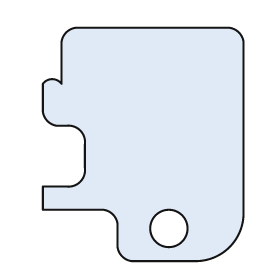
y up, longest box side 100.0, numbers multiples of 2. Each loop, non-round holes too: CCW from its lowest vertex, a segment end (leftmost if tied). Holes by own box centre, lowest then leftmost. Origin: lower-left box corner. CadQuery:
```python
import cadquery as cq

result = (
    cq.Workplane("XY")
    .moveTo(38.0, 0.0)
    .lineTo(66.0, 0.0)
    .threePointArc((80.0, 6.0), (86.0, 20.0))
    .lineTo(86.0, 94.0)
    .threePointArc((84.0, 98.0), (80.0, 100.0))
    .lineTo(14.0, 100.0)
    .threePointArc((10.0, 98.0), (8.0, 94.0))
    .lineTo(8.0, 76.0)
    .threePointArc((4.0, 78.0), (0.0, 76.0))
    .lineTo(0.0, 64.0)
    .threePointArc((2.0, 60.0), (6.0, 58.0))
    .lineTo(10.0, 58.0)
    .threePointArc((16.0, 56.0), (18.0, 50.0))
    .lineTo(18.0, 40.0)
    .threePointArc((16.0, 34.0), (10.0, 32.0))
    .lineTo(0.0, 32.0)
    .lineTo(0.0, 22.0)
    .lineTo(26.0, 22.0)
    .threePointArc((30.0, 20.0), (32.0, 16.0))
    .lineTo(32.0, 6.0)
    .threePointArc((34.0, 2.0), (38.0, 0.0))
    .close()
    .moveTo(54.0, 14.0)
    .circle(8.0)
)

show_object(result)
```